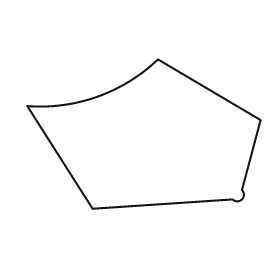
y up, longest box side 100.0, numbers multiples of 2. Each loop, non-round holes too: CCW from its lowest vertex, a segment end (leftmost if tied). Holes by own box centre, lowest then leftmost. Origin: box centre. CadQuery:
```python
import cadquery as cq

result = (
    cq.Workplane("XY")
    .moveTo(-22.0, -32.0)
    .lineTo(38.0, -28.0)
    .threePointArc((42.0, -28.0), (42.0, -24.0))
    .lineTo(50.0, 6.0)
    .lineTo(6.0, 32.0)
    .threePointArc((-20.0, 16.0), (-50.0, 12.0))
    .close()
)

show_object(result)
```